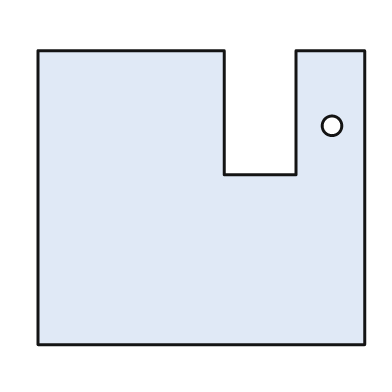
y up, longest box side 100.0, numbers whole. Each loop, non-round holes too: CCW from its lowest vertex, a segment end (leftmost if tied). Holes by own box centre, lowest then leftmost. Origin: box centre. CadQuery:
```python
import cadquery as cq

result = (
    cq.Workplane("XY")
    .moveTo(-50.0, -45.0)
    .lineTo(50.0, -45.0)
    .lineTo(50.0, 45.0)
    .lineTo(29.0, 45.0)
    .lineTo(29.0, 7.0)
    .lineTo(7.0, 7.0)
    .lineTo(7.0, 45.0)
    .lineTo(-50.0, 45.0)
    .close()
    .moveTo(40.0, 22.0)
    .circle(3.0)
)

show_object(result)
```